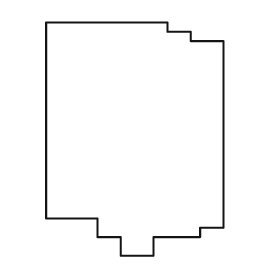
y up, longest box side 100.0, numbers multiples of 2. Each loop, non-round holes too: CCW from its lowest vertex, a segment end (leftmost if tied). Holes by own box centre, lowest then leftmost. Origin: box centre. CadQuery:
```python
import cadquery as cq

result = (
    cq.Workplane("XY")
    .moveTo(-6.0, -50.0)
    .lineTo(8.0, -50.0)
    .lineTo(8.0, -42.0)
    .lineTo(28.0, -42.0)
    .lineTo(28.0, -38.0)
    .lineTo(38.0, -38.0)
    .lineTo(38.0, 42.0)
    .lineTo(24.0, 42.0)
    .lineTo(24.0, 46.0)
    .lineTo(14.0, 46.0)
    .lineTo(14.0, 50.0)
    .lineTo(-38.0, 50.0)
    .lineTo(-38.0, -34.0)
    .lineTo(-16.0, -34.0)
    .lineTo(-16.0, -42.0)
    .lineTo(-6.0, -42.0)
    .close()
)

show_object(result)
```